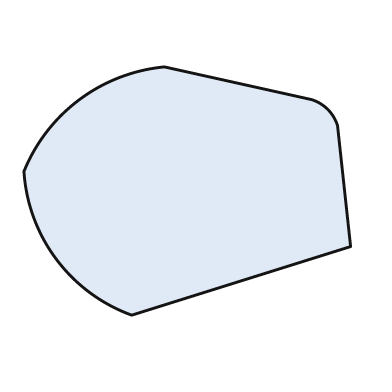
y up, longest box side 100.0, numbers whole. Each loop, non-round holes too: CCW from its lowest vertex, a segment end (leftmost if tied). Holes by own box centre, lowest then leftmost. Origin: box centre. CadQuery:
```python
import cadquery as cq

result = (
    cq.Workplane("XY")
    .moveTo(-17.0, -38.0)
    .lineTo(50.0, -17.0)
    .lineTo(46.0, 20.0)
    .threePointArc((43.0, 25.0), (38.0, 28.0))
    .lineTo(-7.0, 38.0)
    .threePointArc((-33.0, 28.0), (-50.0, 6.0))
    .threePointArc((-40.0, -21.0), (-17.0, -38.0))
    .close()
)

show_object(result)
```